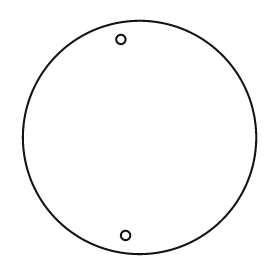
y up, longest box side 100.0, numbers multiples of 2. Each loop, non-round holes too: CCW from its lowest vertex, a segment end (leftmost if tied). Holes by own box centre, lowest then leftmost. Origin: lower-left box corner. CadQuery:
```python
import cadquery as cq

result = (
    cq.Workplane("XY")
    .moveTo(50.0, 50.0)
    .circle(50.0)
    .moveTo(44.0, 8.0)
    .circle(2.0)
    .moveTo(42.0, 92.0)
    .circle(2.0)
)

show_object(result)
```